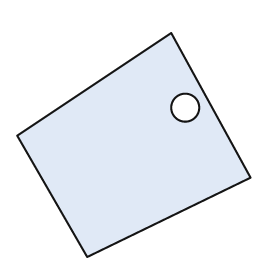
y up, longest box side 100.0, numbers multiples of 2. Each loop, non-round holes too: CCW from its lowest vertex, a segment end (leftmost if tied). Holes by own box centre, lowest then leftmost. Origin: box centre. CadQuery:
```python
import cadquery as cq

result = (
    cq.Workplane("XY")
    .moveTo(-20.0, -48.0)
    .lineTo(50.0, -14.0)
    .lineTo(16.0, 48.0)
    .lineTo(-50.0, 4.0)
    .close()
    .moveTo(22.0, 16.0)
    .circle(6.0)
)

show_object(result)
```